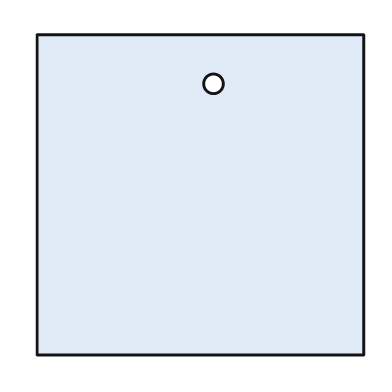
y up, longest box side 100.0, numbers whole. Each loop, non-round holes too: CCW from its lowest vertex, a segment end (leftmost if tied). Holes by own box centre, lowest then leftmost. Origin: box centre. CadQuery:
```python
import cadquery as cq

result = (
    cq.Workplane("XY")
    .moveTo(-50.0, -49.0)
    .lineTo(50.0, -49.0)
    .lineTo(50.0, 49.0)
    .lineTo(-50.0, 49.0)
    .close()
    .moveTo(4.0, 34.0)
    .circle(3.0)
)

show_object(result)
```